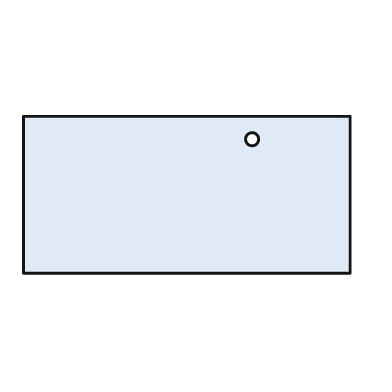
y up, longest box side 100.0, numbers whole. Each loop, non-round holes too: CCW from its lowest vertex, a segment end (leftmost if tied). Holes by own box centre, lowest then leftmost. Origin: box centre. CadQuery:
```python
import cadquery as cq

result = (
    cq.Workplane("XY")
    .moveTo(-50.0, -24.0)
    .lineTo(50.0, -24.0)
    .lineTo(50.0, 24.0)
    .lineTo(-50.0, 24.0)
    .close()
    .moveTo(20.0, 17.0)
    .circle(2.0)
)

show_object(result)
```